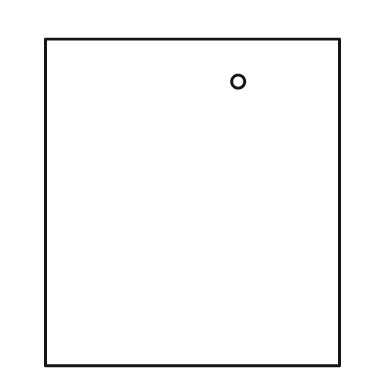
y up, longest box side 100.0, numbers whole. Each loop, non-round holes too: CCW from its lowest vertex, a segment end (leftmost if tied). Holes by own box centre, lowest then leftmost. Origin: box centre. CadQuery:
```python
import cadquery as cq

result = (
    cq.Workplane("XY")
    .moveTo(-45.0, -50.0)
    .lineTo(45.0, -50.0)
    .lineTo(45.0, 50.0)
    .lineTo(-45.0, 50.0)
    .close()
    .moveTo(14.0, 37.0)
    .circle(2.0)
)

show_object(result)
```